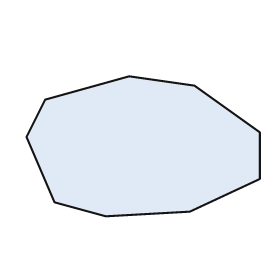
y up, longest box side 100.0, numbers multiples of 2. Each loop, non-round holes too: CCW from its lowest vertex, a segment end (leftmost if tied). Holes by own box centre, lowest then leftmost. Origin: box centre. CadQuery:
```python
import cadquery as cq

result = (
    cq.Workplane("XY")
    .moveTo(-16.0, -30.0)
    .lineTo(20.0, -28.0)
    .lineTo(50.0, -14.0)
    .lineTo(50.0, 6.0)
    .lineTo(22.0, 26.0)
    .lineTo(-6.0, 30.0)
    .lineTo(-42.0, 20.0)
    .lineTo(-50.0, 4.0)
    .lineTo(-38.0, -24.0)
    .close()
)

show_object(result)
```